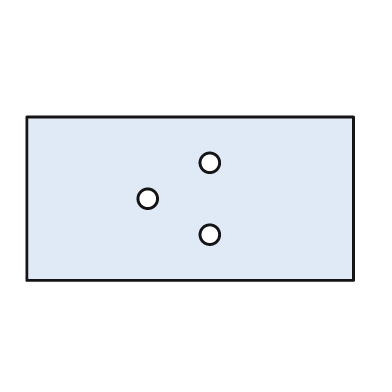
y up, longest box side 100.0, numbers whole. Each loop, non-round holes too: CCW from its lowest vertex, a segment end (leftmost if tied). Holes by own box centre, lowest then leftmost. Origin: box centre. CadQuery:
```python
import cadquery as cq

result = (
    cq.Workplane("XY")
    .moveTo(-50.0, -25.0)
    .lineTo(50.0, -25.0)
    .lineTo(50.0, 25.0)
    .lineTo(-50.0, 25.0)
    .close()
    .moveTo(6.0, -11.0)
    .circle(3.0)
    .moveTo(-13.0, 0.0)
    .circle(3.0)
    .moveTo(6.0, 11.0)
    .circle(3.0)
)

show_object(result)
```